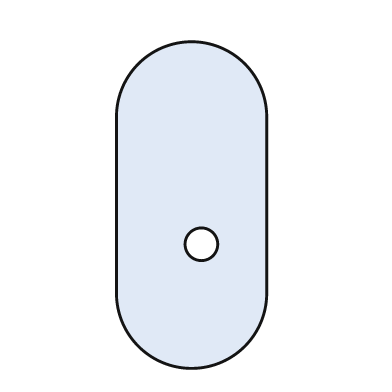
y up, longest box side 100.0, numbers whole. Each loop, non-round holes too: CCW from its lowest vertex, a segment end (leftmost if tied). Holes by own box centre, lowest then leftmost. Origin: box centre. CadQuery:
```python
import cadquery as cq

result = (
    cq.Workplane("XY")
    .moveTo(-23.0, -27.0)
    .threePointArc((0.0, -50.0), (23.0, -27.0))
    .lineTo(23.0, 27.0)
    .threePointArc((0.0, 50.0), (-23.0, 27.0))
    .close()
    .moveTo(3.0, -12.0)
    .circle(5.0)
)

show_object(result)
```